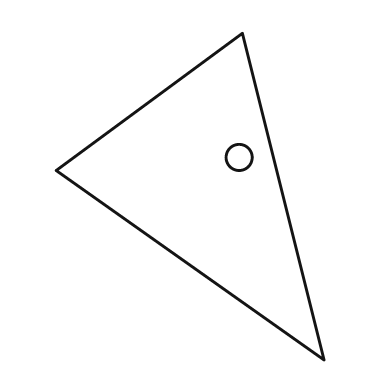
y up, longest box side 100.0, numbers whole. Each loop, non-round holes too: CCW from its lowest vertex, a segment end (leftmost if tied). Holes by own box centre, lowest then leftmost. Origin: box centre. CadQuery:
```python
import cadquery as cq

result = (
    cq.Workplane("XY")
    .moveTo(41.0, -50.0)
    .lineTo(16.0, 50.0)
    .lineTo(-41.0, 8.0)
    .close()
    .moveTo(15.0, 12.0)
    .circle(4.0)
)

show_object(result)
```